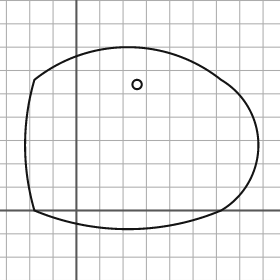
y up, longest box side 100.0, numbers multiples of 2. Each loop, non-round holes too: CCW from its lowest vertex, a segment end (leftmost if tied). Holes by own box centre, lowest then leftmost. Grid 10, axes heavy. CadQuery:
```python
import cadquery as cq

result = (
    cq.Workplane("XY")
    .moveTo(-18.0, 0.0)
    .threePointArc((22.0, -8.0), (62.0, 0.0))
    .threePointArc((78.0, 28.0), (62.0, 56.0))
    .threePointArc((22.0, 70.0), (-18.0, 56.0))
    .threePointArc((-22.0, 28.0), (-18.0, 0.0))
    .close()
    .moveTo(26.0, 54.0)
    .circle(2.0)
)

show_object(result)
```